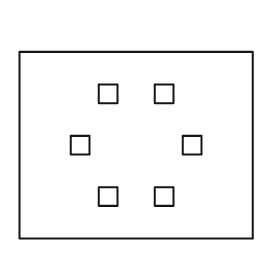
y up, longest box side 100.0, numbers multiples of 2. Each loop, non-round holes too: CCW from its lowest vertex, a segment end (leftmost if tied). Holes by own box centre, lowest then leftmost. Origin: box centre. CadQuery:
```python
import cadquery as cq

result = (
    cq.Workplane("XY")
    .moveTo(-50.0, -40.0)
    .lineTo(50.0, -40.0)
    .lineTo(50.0, 40.0)
    .lineTo(-50.0, 40.0)
    .close()
    .moveTo(-16.0, -26.0)
    .lineTo(-8.0, -26.0)
    .lineTo(-8.0, -18.0)
    .lineTo(-16.0, -18.0)
    .close()
    .moveTo(8.0, -26.0)
    .lineTo(16.0, -26.0)
    .lineTo(16.0, -18.0)
    .lineTo(8.0, -18.0)
    .close()
    .moveTo(-28.0, -4.0)
    .lineTo(-20.0, -4.0)
    .lineTo(-20.0, 4.0)
    .lineTo(-28.0, 4.0)
    .close()
    .moveTo(20.0, -4.0)
    .lineTo(28.0, -4.0)
    .lineTo(28.0, 4.0)
    .lineTo(20.0, 4.0)
    .close()
    .moveTo(-16.0, 18.0)
    .lineTo(-8.0, 18.0)
    .lineTo(-8.0, 26.0)
    .lineTo(-16.0, 26.0)
    .close()
    .moveTo(8.0, 18.0)
    .lineTo(16.0, 18.0)
    .lineTo(16.0, 26.0)
    .lineTo(8.0, 26.0)
    .close()
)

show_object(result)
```